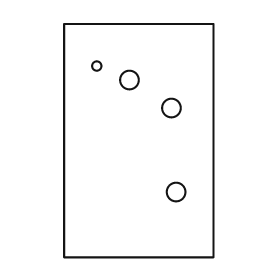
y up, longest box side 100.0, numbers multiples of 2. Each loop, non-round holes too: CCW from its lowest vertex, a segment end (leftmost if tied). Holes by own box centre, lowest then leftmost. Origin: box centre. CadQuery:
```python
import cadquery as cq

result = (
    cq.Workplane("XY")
    .moveTo(-32.0, -50.0)
    .lineTo(32.0, -50.0)
    .lineTo(32.0, 50.0)
    .lineTo(-32.0, 50.0)
    .close()
    .moveTo(16.0, -22.0)
    .circle(4.0)
    .moveTo(14.0, 14.0)
    .circle(4.0)
    .moveTo(-4.0, 26.0)
    .circle(4.0)
    .moveTo(-18.0, 32.0)
    .circle(2.0)
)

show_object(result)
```